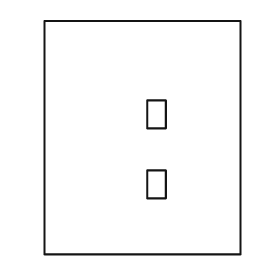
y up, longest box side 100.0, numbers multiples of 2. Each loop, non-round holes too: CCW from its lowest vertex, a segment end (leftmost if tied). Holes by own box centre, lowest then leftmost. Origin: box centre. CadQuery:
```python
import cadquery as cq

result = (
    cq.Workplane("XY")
    .moveTo(-42.0, -50.0)
    .lineTo(42.0, -50.0)
    .lineTo(42.0, 50.0)
    .lineTo(-42.0, 50.0)
    .close()
    .moveTo(2.0, -26.0)
    .lineTo(10.0, -26.0)
    .lineTo(10.0, -14.0)
    .lineTo(2.0, -14.0)
    .close()
    .moveTo(2.0, 4.0)
    .lineTo(10.0, 4.0)
    .lineTo(10.0, 16.0)
    .lineTo(2.0, 16.0)
    .close()
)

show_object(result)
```